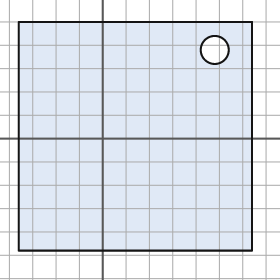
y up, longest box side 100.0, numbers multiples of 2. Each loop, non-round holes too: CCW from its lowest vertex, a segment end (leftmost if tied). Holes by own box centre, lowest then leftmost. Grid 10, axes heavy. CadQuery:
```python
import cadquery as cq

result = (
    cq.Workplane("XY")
    .moveTo(-36.0, -48.0)
    .lineTo(64.0, -48.0)
    .lineTo(64.0, 50.0)
    .lineTo(-36.0, 50.0)
    .close()
    .moveTo(48.0, 38.0)
    .circle(6.0)
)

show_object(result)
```